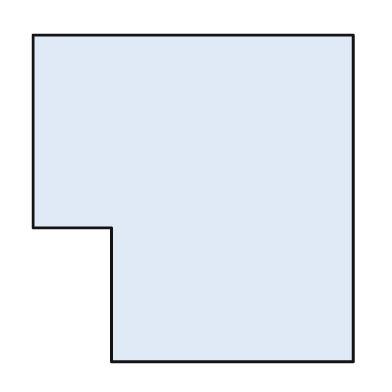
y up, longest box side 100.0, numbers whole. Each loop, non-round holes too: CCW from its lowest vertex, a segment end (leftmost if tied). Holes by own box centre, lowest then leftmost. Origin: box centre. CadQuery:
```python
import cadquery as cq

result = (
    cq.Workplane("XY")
    .moveTo(-25.0, -50.0)
    .lineTo(49.0, -50.0)
    .lineTo(49.0, 50.0)
    .lineTo(-49.0, 50.0)
    .lineTo(-49.0, -9.0)
    .lineTo(-25.0, -9.0)
    .close()
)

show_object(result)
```